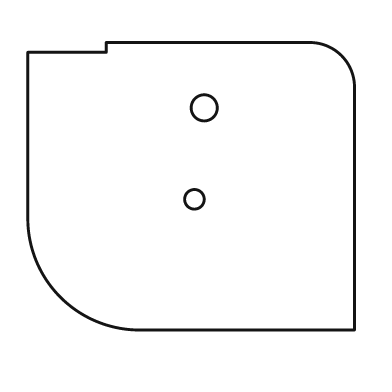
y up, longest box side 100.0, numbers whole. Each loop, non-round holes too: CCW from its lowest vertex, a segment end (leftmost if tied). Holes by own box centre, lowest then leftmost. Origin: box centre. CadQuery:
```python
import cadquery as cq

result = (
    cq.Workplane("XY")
    .moveTo(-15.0, -44.0)
    .lineTo(50.0, -44.0)
    .lineTo(50.0, 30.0)
    .threePointArc((46.0, 40.0), (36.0, 44.0))
    .lineTo(-26.0, 44.0)
    .lineTo(-26.0, 41.0)
    .lineTo(-50.0, 41.0)
    .lineTo(-50.0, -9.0)
    .threePointArc((-40.0, -34.0), (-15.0, -44.0))
    .close()
    .moveTo(1.0, -4.0)
    .circle(3.0)
    .moveTo(4.0, 24.0)
    .circle(4.0)
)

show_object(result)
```